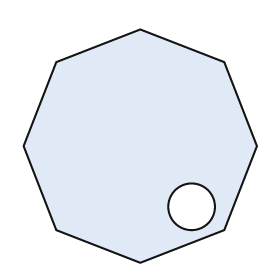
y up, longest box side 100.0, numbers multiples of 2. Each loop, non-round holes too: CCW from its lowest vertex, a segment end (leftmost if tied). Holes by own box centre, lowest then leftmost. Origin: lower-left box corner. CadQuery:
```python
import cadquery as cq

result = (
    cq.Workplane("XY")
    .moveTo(50.0, 0.0)
    .lineTo(86.0, 14.0)
    .lineTo(100.0, 50.0)
    .lineTo(86.0, 86.0)
    .lineTo(50.0, 100.0)
    .lineTo(14.0, 86.0)
    .lineTo(0.0, 50.0)
    .lineTo(14.0, 14.0)
    .close()
    .moveTo(72.0, 24.0)
    .circle(10.0)
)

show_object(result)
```